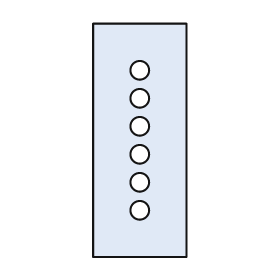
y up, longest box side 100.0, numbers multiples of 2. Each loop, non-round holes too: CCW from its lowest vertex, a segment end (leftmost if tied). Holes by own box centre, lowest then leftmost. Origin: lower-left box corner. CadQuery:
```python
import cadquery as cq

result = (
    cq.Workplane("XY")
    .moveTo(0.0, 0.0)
    .lineTo(40.0, 0.0)
    .lineTo(40.0, 100.0)
    .lineTo(0.0, 100.0)
    .close()
    .moveTo(20.0, 20.0)
    .circle(4.0)
    .moveTo(20.0, 32.0)
    .circle(4.0)
    .moveTo(20.0, 44.0)
    .circle(4.0)
    .moveTo(20.0, 56.0)
    .circle(4.0)
    .moveTo(20.0, 68.0)
    .circle(4.0)
    .moveTo(20.0, 80.0)
    .circle(4.0)
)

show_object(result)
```